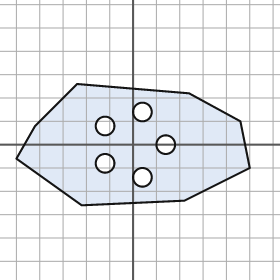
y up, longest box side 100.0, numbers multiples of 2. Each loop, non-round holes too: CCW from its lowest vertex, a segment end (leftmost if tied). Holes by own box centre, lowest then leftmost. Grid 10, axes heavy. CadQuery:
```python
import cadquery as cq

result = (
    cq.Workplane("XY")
    .moveTo(-22.0, -26.0)
    .lineTo(22.0, -24.0)
    .lineTo(50.0, -10.0)
    .lineTo(46.0, 10.0)
    .lineTo(24.0, 22.0)
    .lineTo(-24.0, 26.0)
    .lineTo(-42.0, 8.0)
    .lineTo(-50.0, -6.0)
    .close()
    .moveTo(4.0, -14.0)
    .circle(4.0)
    .moveTo(-12.0, -8.0)
    .circle(4.0)
    .moveTo(14.0, 0.0)
    .circle(4.0)
    .moveTo(-12.0, 8.0)
    .circle(4.0)
    .moveTo(4.0, 14.0)
    .circle(4.0)
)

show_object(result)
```